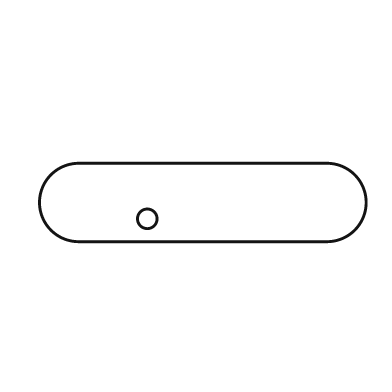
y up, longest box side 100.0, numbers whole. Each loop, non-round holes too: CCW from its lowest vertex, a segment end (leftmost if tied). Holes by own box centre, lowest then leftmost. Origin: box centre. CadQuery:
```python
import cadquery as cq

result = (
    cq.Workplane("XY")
    .moveTo(-38.0, -12.0)
    .lineTo(38.0, -12.0)
    .threePointArc((50.0, 0.0), (38.0, 12.0))
    .lineTo(-38.0, 12.0)
    .threePointArc((-50.0, 0.0), (-38.0, -12.0))
    .close()
    .moveTo(-17.0, -5.0)
    .circle(3.0)
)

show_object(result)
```